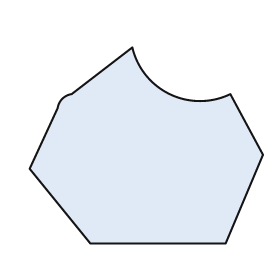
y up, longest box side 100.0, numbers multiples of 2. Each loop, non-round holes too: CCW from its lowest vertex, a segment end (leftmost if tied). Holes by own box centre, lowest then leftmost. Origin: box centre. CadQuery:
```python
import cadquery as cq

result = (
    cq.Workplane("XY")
    .moveTo(-24.0, -42.0)
    .lineTo(34.0, -42.0)
    .lineTo(50.0, -4.0)
    .lineTo(36.0, 22.0)
    .threePointArc((10.0, 22.0), (-6.0, 42.0))
    .lineTo(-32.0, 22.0)
    .threePointArc((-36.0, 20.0), (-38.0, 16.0))
    .lineTo(-50.0, -10.0)
    .close()
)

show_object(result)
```